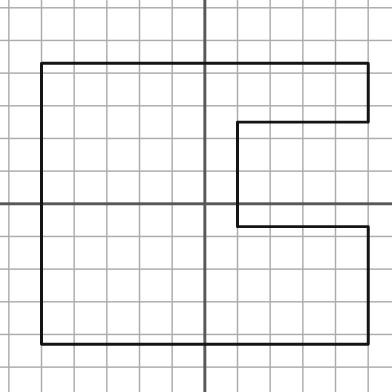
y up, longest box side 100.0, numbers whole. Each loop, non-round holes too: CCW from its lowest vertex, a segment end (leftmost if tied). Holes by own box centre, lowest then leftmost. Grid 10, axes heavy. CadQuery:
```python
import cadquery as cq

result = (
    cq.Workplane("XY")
    .moveTo(-50.0, -43.0)
    .lineTo(50.0, -43.0)
    .lineTo(50.0, -7.0)
    .lineTo(10.0, -7.0)
    .lineTo(10.0, 25.0)
    .lineTo(50.0, 25.0)
    .lineTo(50.0, 43.0)
    .lineTo(-50.0, 43.0)
    .close()
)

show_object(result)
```